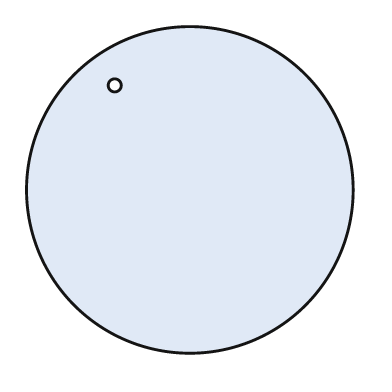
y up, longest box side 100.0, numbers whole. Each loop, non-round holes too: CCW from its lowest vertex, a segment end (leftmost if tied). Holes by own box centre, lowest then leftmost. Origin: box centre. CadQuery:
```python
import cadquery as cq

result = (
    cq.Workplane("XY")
    .moveTo(0.0, 0.0)
    .circle(50.0)
    .moveTo(-23.0, 32.0)
    .circle(2.0)
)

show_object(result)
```